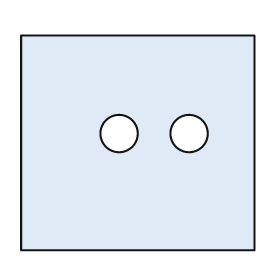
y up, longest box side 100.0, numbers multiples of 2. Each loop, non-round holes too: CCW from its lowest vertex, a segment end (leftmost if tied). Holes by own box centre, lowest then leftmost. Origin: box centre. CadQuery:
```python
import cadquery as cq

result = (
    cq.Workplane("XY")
    .moveTo(-50.0, -46.0)
    .lineTo(50.0, -46.0)
    .lineTo(50.0, 46.0)
    .lineTo(-50.0, 46.0)
    .close()
    .moveTo(-8.0, 4.0)
    .circle(8.0)
    .moveTo(22.0, 4.0)
    .circle(8.0)
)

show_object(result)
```